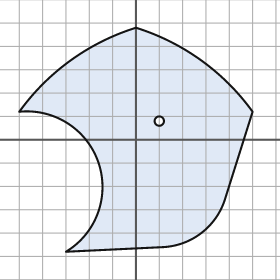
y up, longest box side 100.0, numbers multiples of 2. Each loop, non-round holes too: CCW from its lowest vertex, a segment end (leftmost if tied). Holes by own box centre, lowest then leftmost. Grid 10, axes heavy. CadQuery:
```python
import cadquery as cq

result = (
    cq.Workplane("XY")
    .moveTo(-30.0, -48.0)
    .lineTo(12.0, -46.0)
    .threePointArc((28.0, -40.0), (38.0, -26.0))
    .lineTo(50.0, 12.0)
    .threePointArc((28.0, 34.0), (0.0, 48.0))
    .threePointArc((-28.0, 34.0), (-50.0, 12.0))
    .threePointArc((-16.0, -10.0), (-30.0, -48.0))
    .close()
    .moveTo(10.0, 8.0)
    .circle(2.0)
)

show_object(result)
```